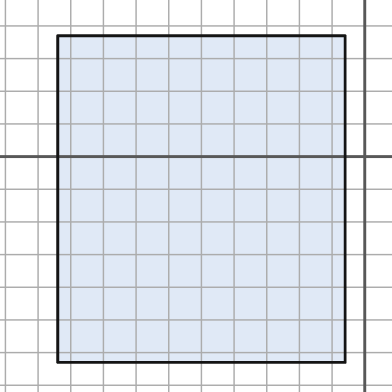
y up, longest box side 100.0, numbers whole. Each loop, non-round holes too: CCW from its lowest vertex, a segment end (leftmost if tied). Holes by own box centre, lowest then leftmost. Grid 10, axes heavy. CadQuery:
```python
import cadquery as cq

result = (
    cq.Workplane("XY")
    .moveTo(-94.0, -63.0)
    .lineTo(-6.0, -63.0)
    .lineTo(-6.0, 37.0)
    .lineTo(-94.0, 37.0)
    .close()
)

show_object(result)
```